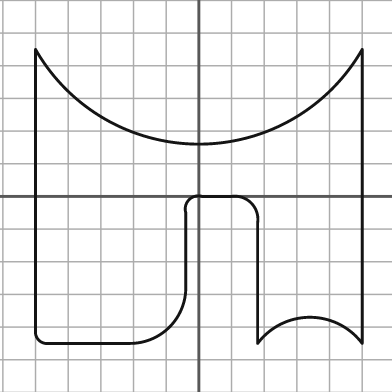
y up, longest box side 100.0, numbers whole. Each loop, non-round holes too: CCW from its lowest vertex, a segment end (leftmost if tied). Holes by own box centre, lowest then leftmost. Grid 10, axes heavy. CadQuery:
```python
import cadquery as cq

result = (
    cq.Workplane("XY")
    .moveTo(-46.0, -45.0)
    .lineTo(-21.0, -45.0)
    .threePointArc((-9.0, -40.0), (-4.0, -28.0))
    .lineTo(-4.0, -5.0)
    .threePointArc((-3.0, -1.0), (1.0, 0.0))
    .lineTo(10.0, 0.0)
    .threePointArc((16.0, -2.0), (18.0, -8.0))
    .lineTo(18.0, -45.0)
    .threePointArc((34.0, -37.0), (50.0, -45.0))
    .lineTo(50.0, 45.0)
    .threePointArc((0.0, 16.0), (-50.0, 45.0))
    .lineTo(-50.0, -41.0)
    .threePointArc((-49.0, -44.0), (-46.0, -45.0))
    .close()
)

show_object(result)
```